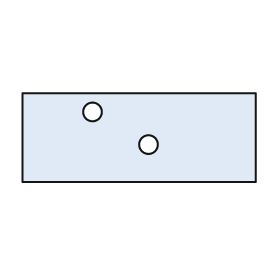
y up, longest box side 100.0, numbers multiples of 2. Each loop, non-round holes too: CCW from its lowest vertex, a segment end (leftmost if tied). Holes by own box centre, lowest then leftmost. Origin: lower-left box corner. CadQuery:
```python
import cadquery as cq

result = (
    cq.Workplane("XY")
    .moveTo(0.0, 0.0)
    .lineTo(100.0, 0.0)
    .lineTo(100.0, 38.0)
    .lineTo(0.0, 38.0)
    .close()
    .moveTo(54.0, 16.0)
    .circle(4.0)
    .moveTo(30.0, 30.0)
    .circle(4.0)
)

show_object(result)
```